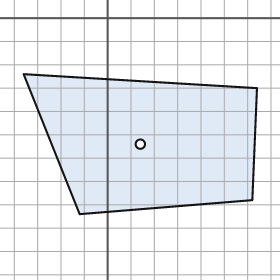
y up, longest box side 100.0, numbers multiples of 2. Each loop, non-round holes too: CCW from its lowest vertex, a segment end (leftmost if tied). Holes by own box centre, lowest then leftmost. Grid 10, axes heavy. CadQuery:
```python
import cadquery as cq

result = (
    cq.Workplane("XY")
    .moveTo(-12.0, -84.0)
    .lineTo(62.0, -78.0)
    .lineTo(64.0, -30.0)
    .lineTo(-36.0, -24.0)
    .close()
    .moveTo(14.0, -54.0)
    .circle(2.0)
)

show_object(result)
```